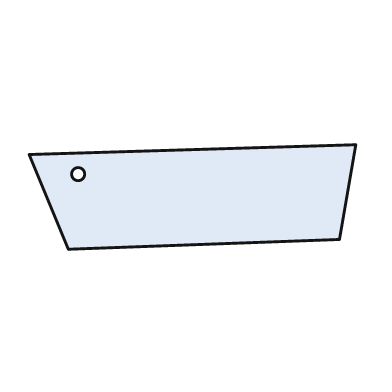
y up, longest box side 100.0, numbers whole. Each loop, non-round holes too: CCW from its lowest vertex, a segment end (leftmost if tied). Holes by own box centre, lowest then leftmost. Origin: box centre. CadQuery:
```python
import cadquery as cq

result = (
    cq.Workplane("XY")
    .moveTo(-38.0, -16.0)
    .lineTo(45.0, -13.0)
    .lineTo(50.0, 16.0)
    .lineTo(-50.0, 13.0)
    .close()
    .moveTo(-35.0, 7.0)
    .circle(2.0)
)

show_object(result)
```